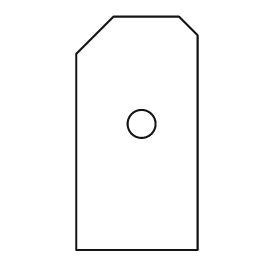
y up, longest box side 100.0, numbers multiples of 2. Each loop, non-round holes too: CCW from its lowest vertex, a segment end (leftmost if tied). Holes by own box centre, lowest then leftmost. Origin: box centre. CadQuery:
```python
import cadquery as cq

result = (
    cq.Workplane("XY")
    .moveTo(-26.0, -50.0)
    .lineTo(26.0, -50.0)
    .lineTo(26.0, 42.0)
    .lineTo(18.0, 50.0)
    .lineTo(-10.0, 50.0)
    .lineTo(-26.0, 34.0)
    .close()
    .moveTo(2.0, 4.0)
    .circle(6.0)
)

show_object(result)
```